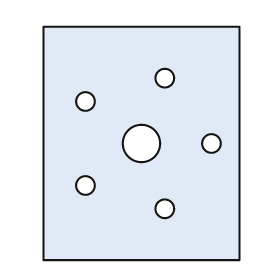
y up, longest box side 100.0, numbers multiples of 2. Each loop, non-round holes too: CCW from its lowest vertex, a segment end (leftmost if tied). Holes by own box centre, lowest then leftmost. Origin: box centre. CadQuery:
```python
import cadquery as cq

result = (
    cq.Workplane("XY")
    .moveTo(-42.0, -50.0)
    .lineTo(42.0, -50.0)
    .lineTo(42.0, 50.0)
    .lineTo(-42.0, 50.0)
    .close()
    .moveTo(10.0, -28.0)
    .circle(4.0)
    .moveTo(-24.0, -18.0)
    .circle(4.0)
    .moveTo(0.0, 0.0)
    .circle(8.0)
    .moveTo(30.0, 0.0)
    .circle(4.0)
    .moveTo(-24.0, 18.0)
    .circle(4.0)
    .moveTo(10.0, 28.0)
    .circle(4.0)
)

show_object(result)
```